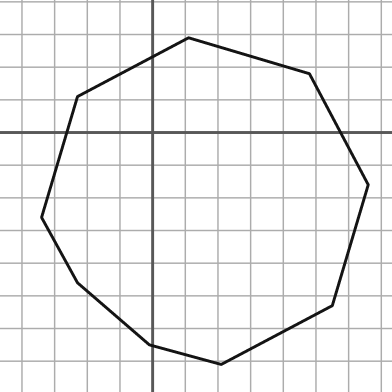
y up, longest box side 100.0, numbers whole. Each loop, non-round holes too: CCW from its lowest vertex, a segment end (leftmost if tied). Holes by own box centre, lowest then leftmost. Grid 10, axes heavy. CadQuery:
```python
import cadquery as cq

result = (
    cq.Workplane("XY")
    .moveTo(21.0, -71.0)
    .lineTo(55.0, -53.0)
    .lineTo(66.0, -16.0)
    .lineTo(48.0, 18.0)
    .lineTo(11.0, 29.0)
    .lineTo(-23.0, 11.0)
    .lineTo(-34.0, -26.0)
    .lineTo(-23.0, -46.0)
    .lineTo(-1.0, -65.0)
    .close()
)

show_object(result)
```